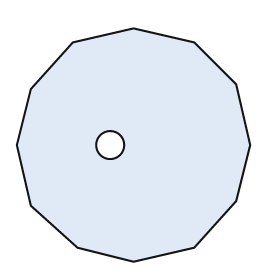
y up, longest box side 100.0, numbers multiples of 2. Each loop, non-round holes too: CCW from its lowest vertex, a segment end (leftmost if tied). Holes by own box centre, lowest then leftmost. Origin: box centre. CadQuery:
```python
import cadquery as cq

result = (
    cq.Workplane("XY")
    .moveTo(0.0, -50.0)
    .lineTo(26.0, -44.0)
    .lineTo(44.0, -24.0)
    .lineTo(50.0, 0.0)
    .lineTo(44.0, 26.0)
    .lineTo(26.0, 44.0)
    .lineTo(0.0, 50.0)
    .lineTo(-26.0, 44.0)
    .lineTo(-44.0, 24.0)
    .lineTo(-50.0, 0.0)
    .lineTo(-44.0, -26.0)
    .lineTo(-24.0, -44.0)
    .close()
    .moveTo(-10.0, 0.0)
    .circle(6.0)
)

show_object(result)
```